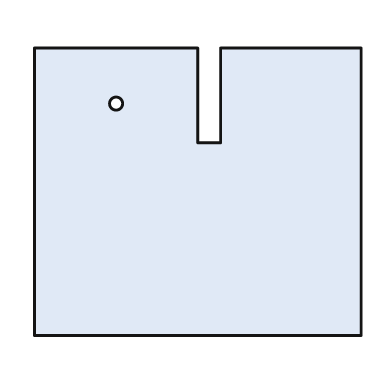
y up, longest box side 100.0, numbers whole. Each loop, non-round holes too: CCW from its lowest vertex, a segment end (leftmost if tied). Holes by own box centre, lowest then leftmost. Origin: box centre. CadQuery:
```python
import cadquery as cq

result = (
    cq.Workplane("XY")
    .moveTo(-50.0, -44.0)
    .lineTo(50.0, -44.0)
    .lineTo(50.0, 44.0)
    .lineTo(7.0, 44.0)
    .lineTo(7.0, 15.0)
    .lineTo(0.0, 15.0)
    .lineTo(0.0, 44.0)
    .lineTo(-50.0, 44.0)
    .close()
    .moveTo(-25.0, 27.0)
    .circle(2.0)
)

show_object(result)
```